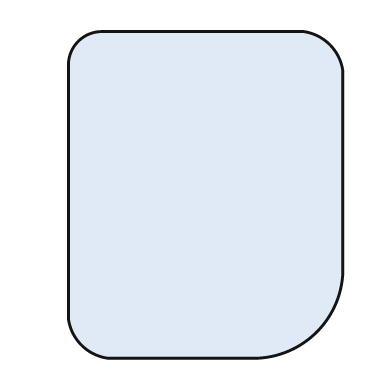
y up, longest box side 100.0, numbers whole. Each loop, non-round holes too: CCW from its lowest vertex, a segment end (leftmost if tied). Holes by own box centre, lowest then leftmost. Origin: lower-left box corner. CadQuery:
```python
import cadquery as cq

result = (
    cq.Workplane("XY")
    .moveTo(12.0, 0.0)
    .lineTo(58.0, 0.0)
    .threePointArc((76.0, 8.0), (84.0, 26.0))
    .lineTo(84.0, 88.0)
    .threePointArc((80.0, 96.0), (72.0, 100.0))
    .lineTo(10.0, 100.0)
    .threePointArc((3.0, 97.0), (0.0, 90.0))
    .lineTo(0.0, 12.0)
    .threePointArc((4.0, 4.0), (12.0, 0.0))
    .close()
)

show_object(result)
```